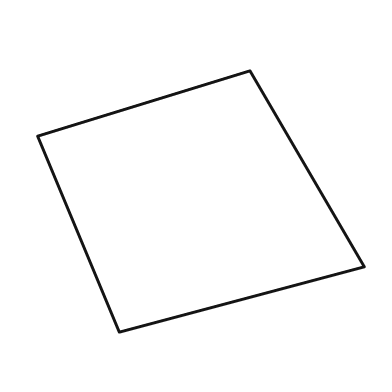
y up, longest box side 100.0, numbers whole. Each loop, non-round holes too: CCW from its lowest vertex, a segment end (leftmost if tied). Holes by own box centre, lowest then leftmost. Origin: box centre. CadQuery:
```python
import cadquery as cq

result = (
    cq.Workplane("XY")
    .moveTo(-25.0, -40.0)
    .lineTo(50.0, -20.0)
    .lineTo(15.0, 40.0)
    .lineTo(-50.0, 20.0)
    .close()
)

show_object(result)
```